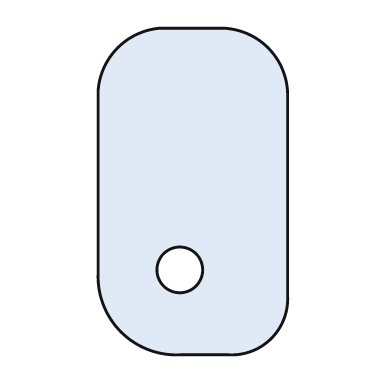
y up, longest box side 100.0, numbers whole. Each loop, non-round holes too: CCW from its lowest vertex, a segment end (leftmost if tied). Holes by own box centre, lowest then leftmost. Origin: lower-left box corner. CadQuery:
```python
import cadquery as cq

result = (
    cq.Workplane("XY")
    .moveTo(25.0, 0.0)
    .lineTo(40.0, 0.0)
    .threePointArc((53.0, 5.0), (58.0, 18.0))
    .lineTo(58.0, 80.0)
    .threePointArc((52.0, 94.0), (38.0, 100.0))
    .lineTo(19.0, 100.0)
    .threePointArc((6.0, 94.0), (0.0, 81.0))
    .lineTo(0.0, 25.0)
    .threePointArc((7.0, 7.0), (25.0, 0.0))
    .close()
    .moveTo(25.0, 26.0)
    .circle(7.0)
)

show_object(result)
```